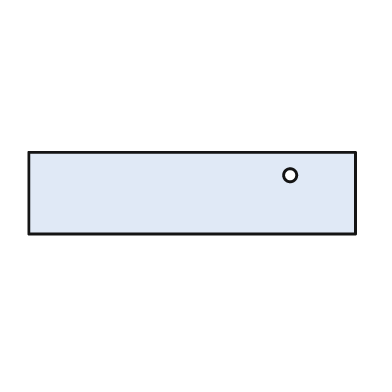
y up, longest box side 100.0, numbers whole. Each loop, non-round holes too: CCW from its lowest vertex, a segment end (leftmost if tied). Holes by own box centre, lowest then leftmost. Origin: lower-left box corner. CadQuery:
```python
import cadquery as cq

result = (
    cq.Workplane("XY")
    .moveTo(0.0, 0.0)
    .lineTo(100.0, 0.0)
    .lineTo(100.0, 25.0)
    .lineTo(0.0, 25.0)
    .close()
    .moveTo(80.0, 18.0)
    .circle(2.0)
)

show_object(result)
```